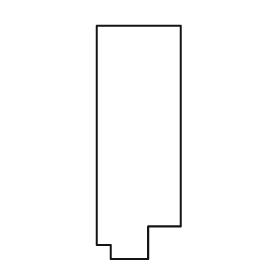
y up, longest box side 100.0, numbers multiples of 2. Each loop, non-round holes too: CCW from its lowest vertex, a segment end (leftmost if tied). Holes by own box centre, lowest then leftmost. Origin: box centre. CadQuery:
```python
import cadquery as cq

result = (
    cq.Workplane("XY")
    .moveTo(-12.0, -50.0)
    .lineTo(4.0, -50.0)
    .lineTo(4.0, -36.0)
    .lineTo(18.0, -36.0)
    .lineTo(18.0, 50.0)
    .lineTo(-18.0, 50.0)
    .lineTo(-18.0, -44.0)
    .lineTo(-12.0, -44.0)
    .close()
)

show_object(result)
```